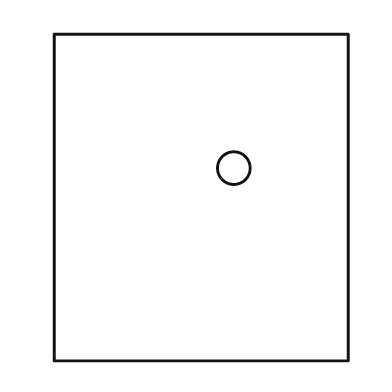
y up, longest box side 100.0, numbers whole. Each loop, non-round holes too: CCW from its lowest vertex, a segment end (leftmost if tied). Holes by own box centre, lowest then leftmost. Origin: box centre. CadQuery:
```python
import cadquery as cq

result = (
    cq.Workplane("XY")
    .moveTo(-45.0, -50.0)
    .lineTo(45.0, -50.0)
    .lineTo(45.0, 50.0)
    .lineTo(-45.0, 50.0)
    .close()
    .moveTo(10.0, 9.0)
    .circle(5.0)
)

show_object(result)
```